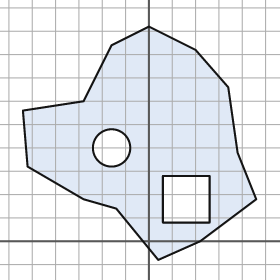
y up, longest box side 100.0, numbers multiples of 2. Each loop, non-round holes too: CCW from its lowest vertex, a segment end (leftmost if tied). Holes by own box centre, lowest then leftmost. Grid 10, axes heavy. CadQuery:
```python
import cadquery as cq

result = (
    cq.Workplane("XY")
    .moveTo(4.0, -8.0)
    .lineTo(22.0, 0.0)
    .lineTo(46.0, 18.0)
    .lineTo(38.0, 38.0)
    .lineTo(34.0, 66.0)
    .lineTo(20.0, 82.0)
    .lineTo(0.0, 92.0)
    .lineTo(-16.0, 84.0)
    .lineTo(-28.0, 60.0)
    .lineTo(-54.0, 56.0)
    .lineTo(-52.0, 32.0)
    .lineTo(-28.0, 18.0)
    .lineTo(-14.0, 14.0)
    .close()
    .moveTo(6.0, 8.0)
    .lineTo(26.0, 8.0)
    .lineTo(26.0, 28.0)
    .lineTo(6.0, 28.0)
    .close()
    .moveTo(-16.0, 40.0)
    .circle(8.0)
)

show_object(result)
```